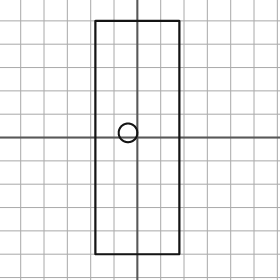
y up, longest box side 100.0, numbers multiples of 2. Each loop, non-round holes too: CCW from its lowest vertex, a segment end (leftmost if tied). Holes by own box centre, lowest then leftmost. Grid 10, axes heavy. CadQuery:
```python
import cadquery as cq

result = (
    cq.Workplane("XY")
    .moveTo(-18.0, -50.0)
    .lineTo(18.0, -50.0)
    .lineTo(18.0, 50.0)
    .lineTo(-18.0, 50.0)
    .close()
    .moveTo(-4.0, 2.0)
    .circle(4.0)
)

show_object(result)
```